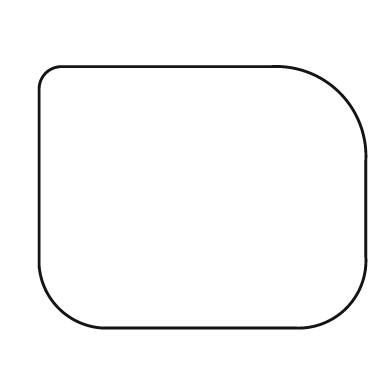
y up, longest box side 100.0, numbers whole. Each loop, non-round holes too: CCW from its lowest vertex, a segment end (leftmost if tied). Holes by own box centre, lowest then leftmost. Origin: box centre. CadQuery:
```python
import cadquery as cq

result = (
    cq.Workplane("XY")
    .moveTo(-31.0, -40.0)
    .lineTo(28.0, -40.0)
    .threePointArc((44.0, -34.0), (50.0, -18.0))
    .lineTo(50.0, 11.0)
    .threePointArc((42.0, 32.0), (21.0, 40.0))
    .lineTo(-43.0, 40.0)
    .threePointArc((-48.0, 38.0), (-50.0, 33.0))
    .lineTo(-50.0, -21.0)
    .threePointArc((-44.0, -34.0), (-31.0, -40.0))
    .close()
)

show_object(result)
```